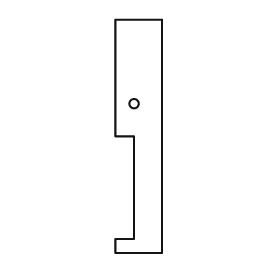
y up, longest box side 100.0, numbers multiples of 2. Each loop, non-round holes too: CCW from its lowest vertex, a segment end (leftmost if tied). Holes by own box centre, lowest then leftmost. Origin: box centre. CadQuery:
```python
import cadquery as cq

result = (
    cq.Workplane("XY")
    .moveTo(-10.0, -50.0)
    .lineTo(10.0, -50.0)
    .lineTo(10.0, 50.0)
    .lineTo(-10.0, 50.0)
    .lineTo(-10.0, 0.0)
    .lineTo(-2.0, 0.0)
    .lineTo(-2.0, -44.0)
    .lineTo(-10.0, -44.0)
    .close()
    .moveTo(-2.0, 14.0)
    .circle(2.0)
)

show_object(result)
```